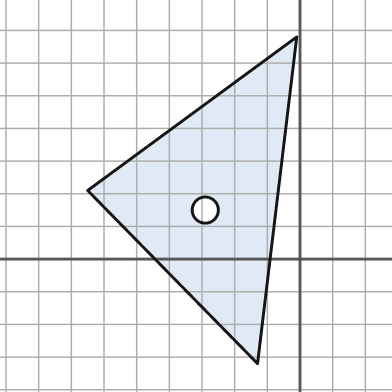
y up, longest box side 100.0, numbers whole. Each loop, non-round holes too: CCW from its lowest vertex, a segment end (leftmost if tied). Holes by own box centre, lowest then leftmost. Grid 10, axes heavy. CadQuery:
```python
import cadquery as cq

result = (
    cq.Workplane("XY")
    .moveTo(-13.0, -32.0)
    .lineTo(-1.0, 68.0)
    .lineTo(-65.0, 21.0)
    .close()
    .moveTo(-29.0, 15.0)
    .circle(4.0)
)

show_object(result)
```